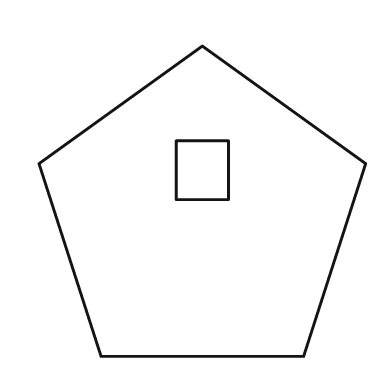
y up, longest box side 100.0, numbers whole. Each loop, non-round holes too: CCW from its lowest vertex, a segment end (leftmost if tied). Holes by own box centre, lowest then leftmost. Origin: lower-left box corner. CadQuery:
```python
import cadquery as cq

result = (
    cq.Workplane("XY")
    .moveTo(19.0, 0.0)
    .lineTo(81.0, 0.0)
    .lineTo(100.0, 59.0)
    .lineTo(50.0, 95.0)
    .lineTo(0.0, 59.0)
    .close()
    .moveTo(42.0, 48.0)
    .lineTo(58.0, 48.0)
    .lineTo(58.0, 66.0)
    .lineTo(42.0, 66.0)
    .close()
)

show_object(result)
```